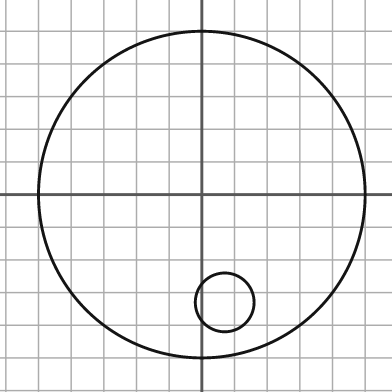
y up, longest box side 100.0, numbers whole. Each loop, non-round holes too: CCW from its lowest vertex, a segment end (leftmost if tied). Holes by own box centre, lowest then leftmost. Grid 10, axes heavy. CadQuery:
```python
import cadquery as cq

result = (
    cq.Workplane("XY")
    .moveTo(0.0, 0.0)
    .circle(50.0)
    .moveTo(7.0, -33.0)
    .circle(9.0)
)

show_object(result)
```